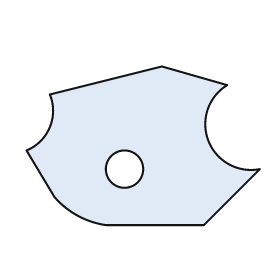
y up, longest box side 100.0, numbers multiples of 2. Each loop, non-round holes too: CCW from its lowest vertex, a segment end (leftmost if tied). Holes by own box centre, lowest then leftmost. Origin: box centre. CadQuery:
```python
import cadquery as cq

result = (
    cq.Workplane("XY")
    .moveTo(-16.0, -34.0)
    .lineTo(26.0, -34.0)
    .lineTo(50.0, -10.0)
    .threePointArc((28.0, 2.0), (36.0, 26.0))
    .lineTo(8.0, 34.0)
    .lineTo(-40.0, 22.0)
    .threePointArc((-40.0, 8.0), (-50.0, -2.0))
    .lineTo(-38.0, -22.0)
    .threePointArc((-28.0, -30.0), (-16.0, -34.0))
    .close()
    .moveTo(-8.0, -10.0)
    .circle(8.0)
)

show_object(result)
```